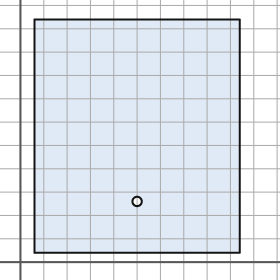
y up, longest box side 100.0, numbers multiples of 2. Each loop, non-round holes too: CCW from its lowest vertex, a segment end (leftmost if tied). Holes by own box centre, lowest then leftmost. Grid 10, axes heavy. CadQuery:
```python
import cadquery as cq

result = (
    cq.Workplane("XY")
    .moveTo(6.0, 4.0)
    .lineTo(94.0, 4.0)
    .lineTo(94.0, 104.0)
    .lineTo(6.0, 104.0)
    .close()
    .moveTo(50.0, 26.0)
    .circle(2.0)
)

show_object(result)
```